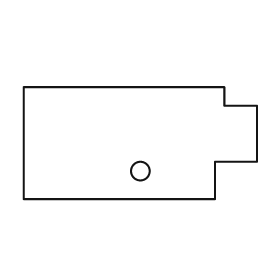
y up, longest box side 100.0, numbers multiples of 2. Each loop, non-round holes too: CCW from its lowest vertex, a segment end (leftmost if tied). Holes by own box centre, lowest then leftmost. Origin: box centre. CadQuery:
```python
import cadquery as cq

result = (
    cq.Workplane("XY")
    .moveTo(-50.0, -24.0)
    .lineTo(32.0, -24.0)
    .lineTo(32.0, -8.0)
    .lineTo(50.0, -8.0)
    .lineTo(50.0, 16.0)
    .lineTo(36.0, 16.0)
    .lineTo(36.0, 24.0)
    .lineTo(-50.0, 24.0)
    .close()
    .moveTo(0.0, -12.0)
    .circle(4.0)
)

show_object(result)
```